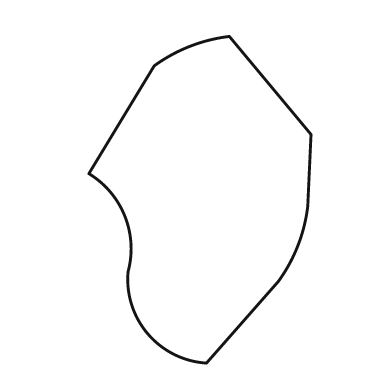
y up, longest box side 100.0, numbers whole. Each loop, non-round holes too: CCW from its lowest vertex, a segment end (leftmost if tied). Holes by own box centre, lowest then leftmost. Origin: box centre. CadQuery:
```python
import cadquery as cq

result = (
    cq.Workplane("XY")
    .moveTo(2.0, -50.0)
    .lineTo(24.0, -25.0)
    .threePointArc((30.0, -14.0), (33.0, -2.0))
    .lineTo(34.0, 20.0)
    .lineTo(9.0, 50.0)
    .threePointArc((-3.0, 47.0), (-14.0, 41.0))
    .lineTo(-34.0, 8.0)
    .threePointArc((-23.0, -5.0), (-22.0, -22.0))
    .threePointArc((-16.0, -41.0), (2.0, -50.0))
    .close()
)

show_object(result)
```